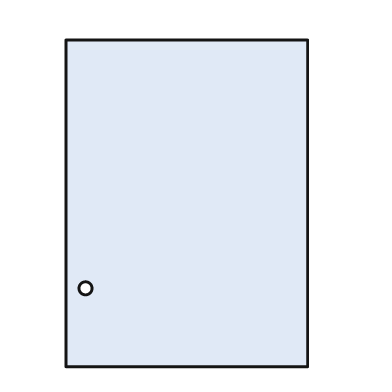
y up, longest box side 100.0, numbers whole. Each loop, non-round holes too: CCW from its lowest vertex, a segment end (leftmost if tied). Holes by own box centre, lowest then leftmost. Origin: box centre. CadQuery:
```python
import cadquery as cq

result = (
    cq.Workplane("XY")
    .moveTo(-37.0, -50.0)
    .lineTo(37.0, -50.0)
    .lineTo(37.0, 50.0)
    .lineTo(-37.0, 50.0)
    .close()
    .moveTo(-31.0, -26.0)
    .circle(2.0)
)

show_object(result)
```